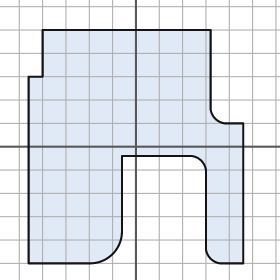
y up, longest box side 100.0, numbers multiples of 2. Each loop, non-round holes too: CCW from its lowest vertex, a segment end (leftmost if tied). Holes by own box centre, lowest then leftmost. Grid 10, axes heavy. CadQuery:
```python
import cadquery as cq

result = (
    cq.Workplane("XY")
    .moveTo(-46.0, -50.0)
    .lineTo(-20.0, -50.0)
    .threePointArc((-10.0, -46.0), (-6.0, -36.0))
    .lineTo(-6.0, -4.0)
    .lineTo(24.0, -4.0)
    .threePointArc((28.0, -6.0), (30.0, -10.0))
    .lineTo(30.0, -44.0)
    .threePointArc((32.0, -48.0), (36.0, -50.0))
    .lineTo(46.0, -50.0)
    .lineTo(46.0, 10.0)
    .lineTo(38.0, 10.0)
    .threePointArc((34.0, 12.0), (32.0, 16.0))
    .lineTo(32.0, 50.0)
    .lineTo(-40.0, 50.0)
    .lineTo(-40.0, 30.0)
    .lineTo(-46.0, 30.0)
    .close()
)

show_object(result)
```